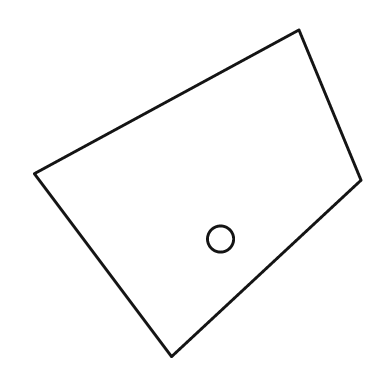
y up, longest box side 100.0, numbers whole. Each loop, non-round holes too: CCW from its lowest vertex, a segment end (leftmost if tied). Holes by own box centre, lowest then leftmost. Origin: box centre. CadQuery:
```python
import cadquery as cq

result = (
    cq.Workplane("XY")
    .moveTo(-8.0, -50.0)
    .lineTo(50.0, 4.0)
    .lineTo(31.0, 50.0)
    .lineTo(-50.0, 6.0)
    .close()
    .moveTo(7.0, -14.0)
    .circle(4.0)
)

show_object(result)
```